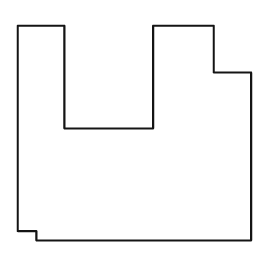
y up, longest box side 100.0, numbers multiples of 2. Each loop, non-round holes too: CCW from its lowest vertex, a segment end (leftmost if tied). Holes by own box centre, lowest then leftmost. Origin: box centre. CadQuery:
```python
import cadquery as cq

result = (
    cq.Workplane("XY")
    .moveTo(-42.0, -46.0)
    .lineTo(50.0, -46.0)
    .lineTo(50.0, 26.0)
    .lineTo(34.0, 26.0)
    .lineTo(34.0, 46.0)
    .lineTo(8.0, 46.0)
    .lineTo(8.0, 2.0)
    .lineTo(-30.0, 2.0)
    .lineTo(-30.0, 46.0)
    .lineTo(-50.0, 46.0)
    .lineTo(-50.0, -42.0)
    .lineTo(-42.0, -42.0)
    .close()
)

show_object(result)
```